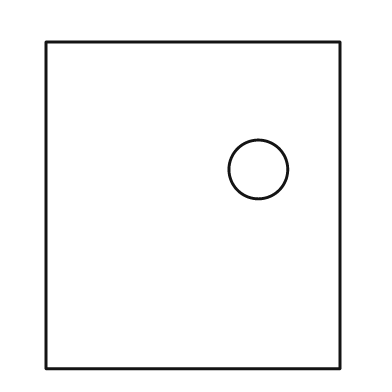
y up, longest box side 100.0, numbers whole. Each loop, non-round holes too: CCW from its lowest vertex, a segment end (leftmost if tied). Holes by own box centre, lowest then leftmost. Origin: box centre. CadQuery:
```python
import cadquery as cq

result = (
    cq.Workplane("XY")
    .moveTo(-45.0, -50.0)
    .lineTo(45.0, -50.0)
    .lineTo(45.0, 50.0)
    .lineTo(-45.0, 50.0)
    .close()
    .moveTo(20.0, 11.0)
    .circle(9.0)
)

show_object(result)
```